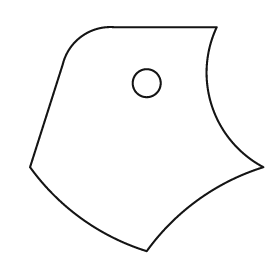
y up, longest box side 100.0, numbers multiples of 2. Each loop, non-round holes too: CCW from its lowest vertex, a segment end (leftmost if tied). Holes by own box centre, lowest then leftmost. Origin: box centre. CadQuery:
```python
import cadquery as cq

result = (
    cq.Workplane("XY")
    .moveTo(0.0, -48.0)
    .threePointArc((22.0, -26.0), (50.0, -12.0))
    .threePointArc((28.0, 14.0), (30.0, 48.0))
    .lineTo(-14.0, 48.0)
    .threePointArc((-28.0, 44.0), (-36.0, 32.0))
    .lineTo(-50.0, -12.0)
    .threePointArc((-28.0, -34.0), (0.0, -48.0))
    .close()
    .moveTo(0.0, 24.0)
    .circle(6.0)
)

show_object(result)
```